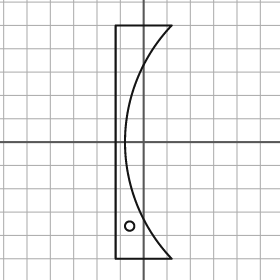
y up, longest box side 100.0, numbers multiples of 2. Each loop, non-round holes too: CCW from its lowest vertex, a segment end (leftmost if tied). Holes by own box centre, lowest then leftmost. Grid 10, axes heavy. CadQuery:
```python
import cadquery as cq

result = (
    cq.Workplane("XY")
    .moveTo(-12.0, -50.0)
    .lineTo(12.0, -50.0)
    .threePointArc((-8.0, 0.0), (12.0, 50.0))
    .lineTo(-12.0, 50.0)
    .close()
    .moveTo(-6.0, -36.0)
    .circle(2.0)
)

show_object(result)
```